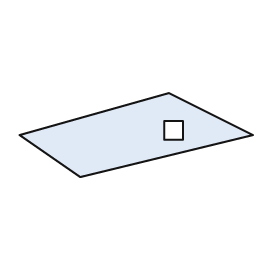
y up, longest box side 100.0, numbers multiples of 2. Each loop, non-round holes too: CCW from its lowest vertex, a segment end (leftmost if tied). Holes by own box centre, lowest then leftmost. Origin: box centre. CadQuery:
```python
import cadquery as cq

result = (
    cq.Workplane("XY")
    .moveTo(-24.0, -18.0)
    .lineTo(50.0, 0.0)
    .lineTo(14.0, 18.0)
    .lineTo(-50.0, 0.0)
    .close()
    .moveTo(12.0, -2.0)
    .lineTo(20.0, -2.0)
    .lineTo(20.0, 6.0)
    .lineTo(12.0, 6.0)
    .close()
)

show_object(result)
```